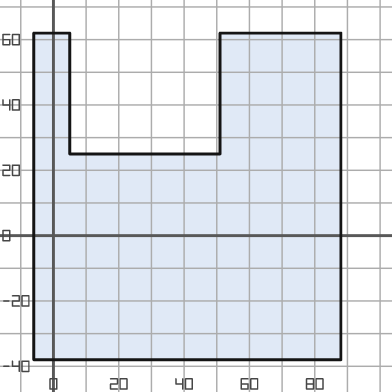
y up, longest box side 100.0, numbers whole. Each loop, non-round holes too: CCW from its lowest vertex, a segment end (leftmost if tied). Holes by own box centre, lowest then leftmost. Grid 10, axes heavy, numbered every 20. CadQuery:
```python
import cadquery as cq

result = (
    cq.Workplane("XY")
    .moveTo(-6.0, -38.0)
    .lineTo(88.0, -38.0)
    .lineTo(88.0, 62.0)
    .lineTo(51.0, 62.0)
    .lineTo(51.0, 25.0)
    .lineTo(5.0, 25.0)
    .lineTo(5.0, 62.0)
    .lineTo(-6.0, 62.0)
    .close()
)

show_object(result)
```